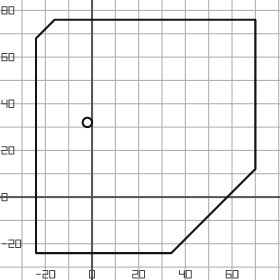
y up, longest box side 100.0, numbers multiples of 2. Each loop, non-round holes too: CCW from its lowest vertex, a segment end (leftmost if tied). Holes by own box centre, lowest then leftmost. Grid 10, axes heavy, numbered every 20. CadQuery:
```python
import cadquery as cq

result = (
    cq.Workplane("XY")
    .moveTo(-24.0, -24.0)
    .lineTo(34.0, -24.0)
    .lineTo(70.0, 12.0)
    .lineTo(70.0, 76.0)
    .lineTo(-16.0, 76.0)
    .lineTo(-24.0, 68.0)
    .close()
    .moveTo(-2.0, 32.0)
    .circle(2.0)
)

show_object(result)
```